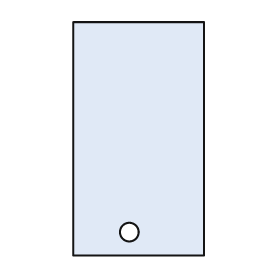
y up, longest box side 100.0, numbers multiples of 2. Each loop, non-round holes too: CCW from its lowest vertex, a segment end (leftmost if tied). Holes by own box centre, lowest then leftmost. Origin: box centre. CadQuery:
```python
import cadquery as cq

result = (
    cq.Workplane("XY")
    .moveTo(-28.0, -50.0)
    .lineTo(28.0, -50.0)
    .lineTo(28.0, 50.0)
    .lineTo(-28.0, 50.0)
    .close()
    .moveTo(-4.0, -40.0)
    .circle(4.0)
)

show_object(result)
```